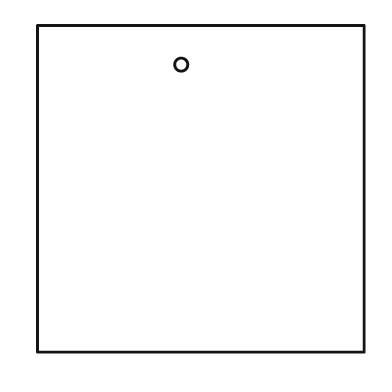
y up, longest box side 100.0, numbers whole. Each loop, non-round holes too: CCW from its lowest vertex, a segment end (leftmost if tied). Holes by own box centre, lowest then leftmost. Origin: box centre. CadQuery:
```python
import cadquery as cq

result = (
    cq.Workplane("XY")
    .moveTo(-50.0, -50.0)
    .lineTo(50.0, -50.0)
    .lineTo(50.0, 50.0)
    .lineTo(-50.0, 50.0)
    .close()
    .moveTo(-6.0, 38.0)
    .circle(2.0)
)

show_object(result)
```